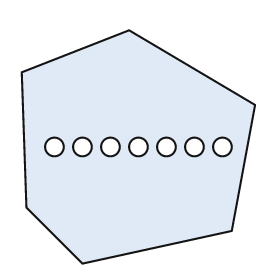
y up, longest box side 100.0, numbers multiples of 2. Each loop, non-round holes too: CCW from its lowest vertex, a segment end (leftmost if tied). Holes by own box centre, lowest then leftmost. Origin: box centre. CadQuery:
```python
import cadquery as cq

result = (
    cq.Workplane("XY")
    .moveTo(-24.0, -50.0)
    .lineTo(40.0, -36.0)
    .lineTo(50.0, 18.0)
    .lineTo(-4.0, 50.0)
    .lineTo(-50.0, 32.0)
    .lineTo(-48.0, -26.0)
    .close()
    .moveTo(-36.0, 0.0)
    .circle(4.0)
    .moveTo(-24.0, 0.0)
    .circle(4.0)
    .moveTo(-12.0, 0.0)
    .circle(4.0)
    .moveTo(0.0, 0.0)
    .circle(4.0)
    .moveTo(12.0, 0.0)
    .circle(4.0)
    .moveTo(24.0, 0.0)
    .circle(4.0)
    .moveTo(36.0, 0.0)
    .circle(4.0)
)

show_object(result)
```